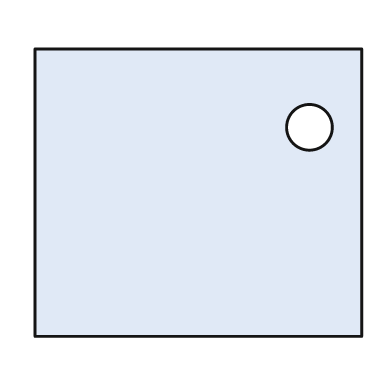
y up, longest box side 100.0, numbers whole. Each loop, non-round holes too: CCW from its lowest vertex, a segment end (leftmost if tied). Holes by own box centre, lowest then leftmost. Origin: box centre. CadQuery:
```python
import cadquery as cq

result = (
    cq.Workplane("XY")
    .moveTo(-50.0, -44.0)
    .lineTo(50.0, -44.0)
    .lineTo(50.0, 44.0)
    .lineTo(-50.0, 44.0)
    .close()
    .moveTo(34.0, 20.0)
    .circle(7.0)
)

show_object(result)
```